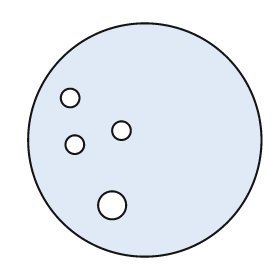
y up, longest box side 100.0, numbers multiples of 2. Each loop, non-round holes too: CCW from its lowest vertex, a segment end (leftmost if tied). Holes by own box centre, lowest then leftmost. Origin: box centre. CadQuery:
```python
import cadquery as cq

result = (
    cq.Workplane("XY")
    .moveTo(0.0, 0.0)
    .circle(50.0)
    .moveTo(-14.0, -28.0)
    .circle(6.0)
    .moveTo(-30.0, -2.0)
    .circle(4.0)
    .moveTo(-10.0, 4.0)
    .circle(4.0)
    .moveTo(-32.0, 18.0)
    .circle(4.0)
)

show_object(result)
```